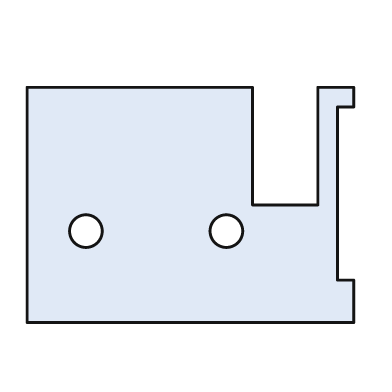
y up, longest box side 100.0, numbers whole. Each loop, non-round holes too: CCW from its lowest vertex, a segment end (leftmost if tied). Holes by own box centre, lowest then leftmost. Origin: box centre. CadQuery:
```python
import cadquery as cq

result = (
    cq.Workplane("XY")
    .moveTo(-50.0, -36.0)
    .lineTo(50.0, -36.0)
    .lineTo(50.0, -23.0)
    .lineTo(45.0, -23.0)
    .lineTo(45.0, 30.0)
    .lineTo(50.0, 30.0)
    .lineTo(50.0, 36.0)
    .lineTo(39.0, 36.0)
    .lineTo(39.0, 0.0)
    .lineTo(19.0, 0.0)
    .lineTo(19.0, 36.0)
    .lineTo(-50.0, 36.0)
    .close()
    .moveTo(-32.0, -8.0)
    .circle(5.0)
    .moveTo(11.0, -8.0)
    .circle(5.0)
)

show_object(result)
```